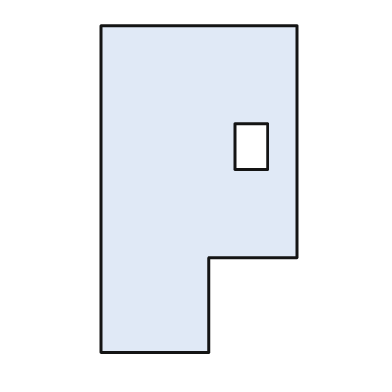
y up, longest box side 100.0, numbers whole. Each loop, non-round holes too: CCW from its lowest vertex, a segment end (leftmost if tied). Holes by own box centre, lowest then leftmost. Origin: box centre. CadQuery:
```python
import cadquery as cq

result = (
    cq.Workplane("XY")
    .moveTo(-30.0, -50.0)
    .lineTo(3.0, -50.0)
    .lineTo(3.0, -21.0)
    .lineTo(30.0, -21.0)
    .lineTo(30.0, 50.0)
    .lineTo(-30.0, 50.0)
    .close()
    .moveTo(11.0, 6.0)
    .lineTo(21.0, 6.0)
    .lineTo(21.0, 20.0)
    .lineTo(11.0, 20.0)
    .close()
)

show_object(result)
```